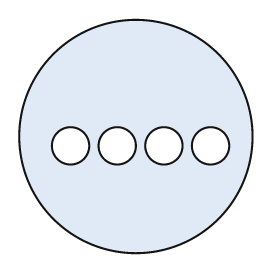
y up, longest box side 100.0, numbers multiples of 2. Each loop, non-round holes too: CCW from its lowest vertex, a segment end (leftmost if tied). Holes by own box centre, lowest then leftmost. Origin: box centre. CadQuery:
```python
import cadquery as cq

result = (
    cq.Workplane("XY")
    .moveTo(0.0, 0.0)
    .circle(50.0)
    .moveTo(-28.0, -4.0)
    .circle(8.0)
    .moveTo(-8.0, -4.0)
    .circle(8.0)
    .moveTo(12.0, -4.0)
    .circle(8.0)
    .moveTo(32.0, -4.0)
    .circle(8.0)
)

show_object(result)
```